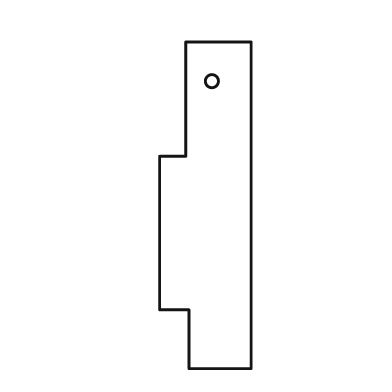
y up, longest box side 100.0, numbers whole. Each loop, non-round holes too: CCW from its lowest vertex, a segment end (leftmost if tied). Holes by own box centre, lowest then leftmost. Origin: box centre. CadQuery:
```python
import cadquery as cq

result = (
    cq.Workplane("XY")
    .moveTo(-5.0, -50.0)
    .lineTo(14.0, -50.0)
    .lineTo(14.0, 50.0)
    .lineTo(-6.0, 50.0)
    .lineTo(-6.0, 15.0)
    .lineTo(-14.0, 15.0)
    .lineTo(-14.0, -32.0)
    .lineTo(-5.0, -32.0)
    .close()
    .moveTo(2.0, 38.0)
    .circle(2.0)
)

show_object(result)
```